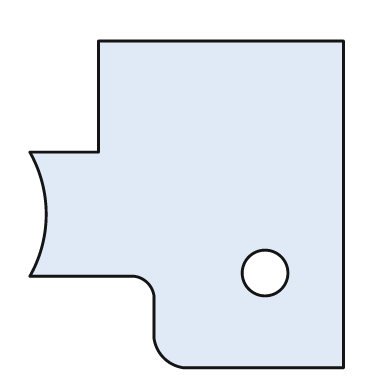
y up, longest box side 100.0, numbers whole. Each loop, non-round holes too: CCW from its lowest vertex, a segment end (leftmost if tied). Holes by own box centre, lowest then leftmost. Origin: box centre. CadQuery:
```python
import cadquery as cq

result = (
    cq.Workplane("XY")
    .moveTo(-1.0, -50.0)
    .lineTo(48.0, -50.0)
    .lineTo(48.0, 50.0)
    .lineTo(-27.0, 50.0)
    .lineTo(-27.0, 16.0)
    .lineTo(-48.0, 16.0)
    .threePointArc((-43.0, -3.0), (-48.0, -22.0))
    .lineTo(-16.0, -22.0)
    .threePointArc((-12.0, -24.0), (-10.0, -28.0))
    .lineTo(-10.0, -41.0)
    .threePointArc((-7.0, -47.0), (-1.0, -50.0))
    .close()
    .moveTo(24.0, -21.0)
    .circle(7.0)
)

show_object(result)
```